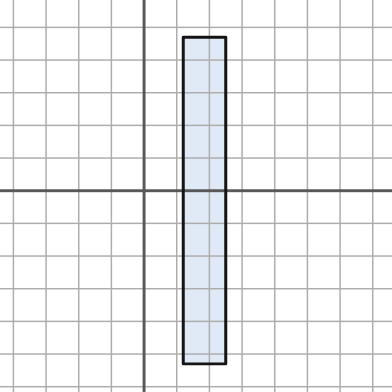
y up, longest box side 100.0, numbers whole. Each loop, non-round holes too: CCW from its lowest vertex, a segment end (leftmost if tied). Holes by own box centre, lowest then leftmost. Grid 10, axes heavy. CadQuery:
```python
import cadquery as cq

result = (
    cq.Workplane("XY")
    .moveTo(12.0, -53.0)
    .lineTo(25.0, -53.0)
    .lineTo(25.0, 47.0)
    .lineTo(12.0, 47.0)
    .close()
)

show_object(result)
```